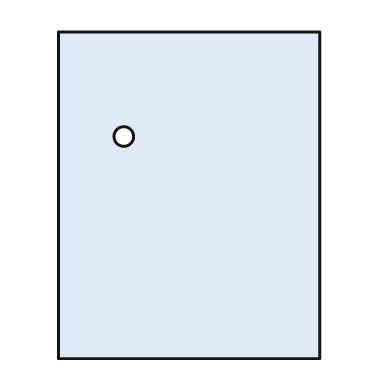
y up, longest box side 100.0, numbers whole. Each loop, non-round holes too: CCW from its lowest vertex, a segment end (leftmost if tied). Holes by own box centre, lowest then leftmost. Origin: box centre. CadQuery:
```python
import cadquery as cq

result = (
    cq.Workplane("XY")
    .moveTo(-40.0, -50.0)
    .lineTo(40.0, -50.0)
    .lineTo(40.0, 50.0)
    .lineTo(-40.0, 50.0)
    .close()
    .moveTo(-20.0, 18.0)
    .circle(3.0)
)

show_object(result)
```